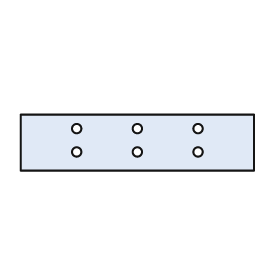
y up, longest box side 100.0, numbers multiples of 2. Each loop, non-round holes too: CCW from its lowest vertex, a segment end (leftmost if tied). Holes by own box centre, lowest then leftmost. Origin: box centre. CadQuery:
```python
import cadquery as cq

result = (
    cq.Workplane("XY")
    .moveTo(-50.0, -12.0)
    .lineTo(50.0, -12.0)
    .lineTo(50.0, 12.0)
    .lineTo(-50.0, 12.0)
    .close()
    .moveTo(-26.0, -4.0)
    .circle(2.0)
    .moveTo(0.0, -4.0)
    .circle(2.0)
    .moveTo(26.0, -4.0)
    .circle(2.0)
    .moveTo(-26.0, 6.0)
    .circle(2.0)
    .moveTo(0.0, 6.0)
    .circle(2.0)
    .moveTo(26.0, 6.0)
    .circle(2.0)
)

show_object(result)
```